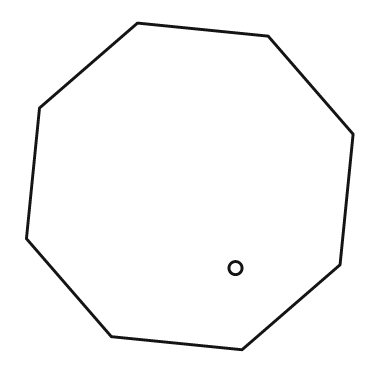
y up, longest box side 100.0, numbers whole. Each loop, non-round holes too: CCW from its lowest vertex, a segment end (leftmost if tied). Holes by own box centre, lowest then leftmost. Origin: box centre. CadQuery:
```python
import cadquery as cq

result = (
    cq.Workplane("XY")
    .moveTo(16.0, -50.0)
    .lineTo(46.0, -24.0)
    .lineTo(50.0, 16.0)
    .lineTo(24.0, 46.0)
    .lineTo(-16.0, 50.0)
    .lineTo(-46.0, 24.0)
    .lineTo(-50.0, -16.0)
    .lineTo(-24.0, -46.0)
    .close()
    .moveTo(14.0, -25.0)
    .circle(2.0)
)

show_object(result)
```